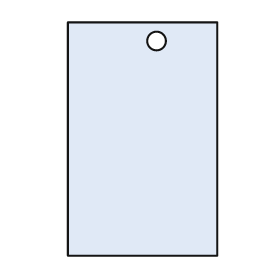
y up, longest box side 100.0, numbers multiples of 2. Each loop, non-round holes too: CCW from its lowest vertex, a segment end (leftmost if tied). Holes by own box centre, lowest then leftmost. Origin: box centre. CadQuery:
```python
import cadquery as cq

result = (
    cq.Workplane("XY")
    .moveTo(-32.0, -50.0)
    .lineTo(32.0, -50.0)
    .lineTo(32.0, 50.0)
    .lineTo(-32.0, 50.0)
    .close()
    .moveTo(6.0, 42.0)
    .circle(4.0)
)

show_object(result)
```